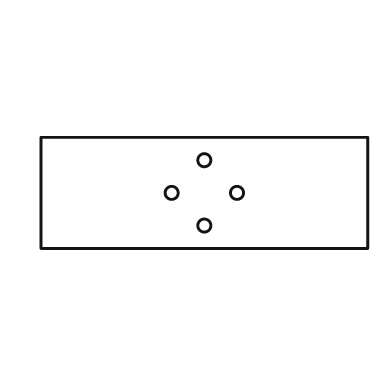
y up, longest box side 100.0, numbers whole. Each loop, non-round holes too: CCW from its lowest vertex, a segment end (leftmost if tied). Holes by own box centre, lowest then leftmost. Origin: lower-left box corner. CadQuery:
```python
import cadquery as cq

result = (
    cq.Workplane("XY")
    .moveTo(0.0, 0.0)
    .lineTo(100.0, 0.0)
    .lineTo(100.0, 34.0)
    .lineTo(0.0, 34.0)
    .close()
    .moveTo(50.0, 7.0)
    .circle(2.0)
    .moveTo(40.0, 17.0)
    .circle(2.0)
    .moveTo(60.0, 17.0)
    .circle(2.0)
    .moveTo(50.0, 27.0)
    .circle(2.0)
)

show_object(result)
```